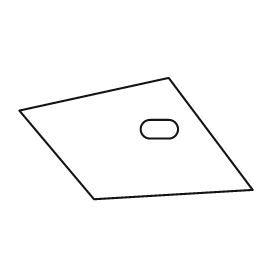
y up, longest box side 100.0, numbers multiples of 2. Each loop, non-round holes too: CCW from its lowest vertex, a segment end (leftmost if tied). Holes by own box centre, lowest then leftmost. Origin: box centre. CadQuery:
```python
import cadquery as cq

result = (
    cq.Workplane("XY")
    .moveTo(-18.0, -26.0)
    .lineTo(50.0, -22.0)
    .lineTo(14.0, 26.0)
    .lineTo(-50.0, 12.0)
    .close()
    .moveTo(6.0, 0.0)
    .lineTo(14.0, 0.0)
    .threePointArc((18.0, 4.0), (14.0, 8.0))
    .lineTo(6.0, 8.0)
    .threePointArc((2.0, 4.0), (6.0, 0.0))
    .close()
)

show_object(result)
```